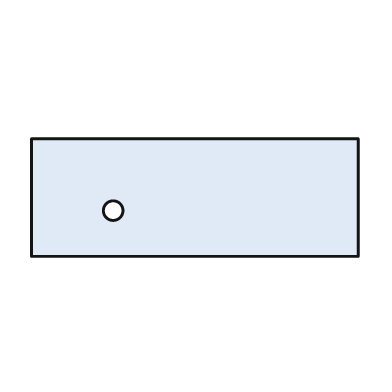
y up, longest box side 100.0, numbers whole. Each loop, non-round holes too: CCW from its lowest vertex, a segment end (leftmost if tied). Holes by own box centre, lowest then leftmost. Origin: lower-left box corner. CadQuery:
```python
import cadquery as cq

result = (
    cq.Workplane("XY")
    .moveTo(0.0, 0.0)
    .lineTo(100.0, 0.0)
    .lineTo(100.0, 36.0)
    .lineTo(0.0, 36.0)
    .close()
    .moveTo(25.0, 14.0)
    .circle(3.0)
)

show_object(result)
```